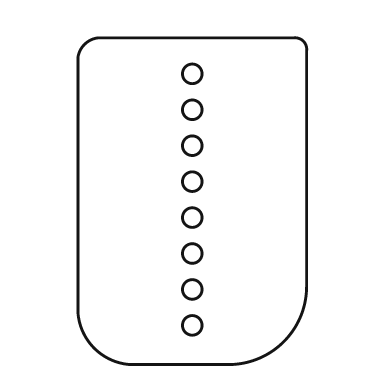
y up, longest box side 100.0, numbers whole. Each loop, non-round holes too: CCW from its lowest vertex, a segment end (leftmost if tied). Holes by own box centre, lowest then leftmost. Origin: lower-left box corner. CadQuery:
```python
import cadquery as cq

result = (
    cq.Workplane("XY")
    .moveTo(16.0, 0.0)
    .lineTo(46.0, 0.0)
    .threePointArc((63.0, 7.0), (70.0, 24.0))
    .lineTo(70.0, 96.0)
    .threePointArc((69.0, 99.0), (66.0, 100.0))
    .lineTo(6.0, 100.0)
    .threePointArc((2.0, 98.0), (0.0, 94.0))
    .lineTo(0.0, 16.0)
    .threePointArc((5.0, 5.0), (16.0, 0.0))
    .close()
    .moveTo(35.0, 12.0)
    .circle(3.0)
    .moveTo(35.0, 23.0)
    .circle(3.0)
    .moveTo(35.0, 34.0)
    .circle(3.0)
    .moveTo(35.0, 45.0)
    .circle(3.0)
    .moveTo(35.0, 56.0)
    .circle(3.0)
    .moveTo(35.0, 67.0)
    .circle(3.0)
    .moveTo(35.0, 78.0)
    .circle(3.0)
    .moveTo(35.0, 89.0)
    .circle(3.0)
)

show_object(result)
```